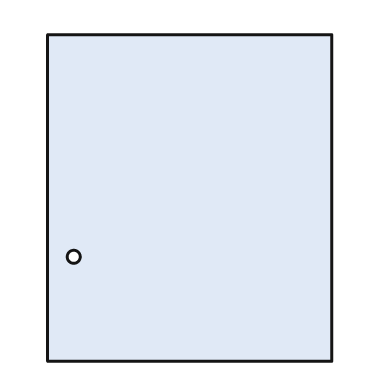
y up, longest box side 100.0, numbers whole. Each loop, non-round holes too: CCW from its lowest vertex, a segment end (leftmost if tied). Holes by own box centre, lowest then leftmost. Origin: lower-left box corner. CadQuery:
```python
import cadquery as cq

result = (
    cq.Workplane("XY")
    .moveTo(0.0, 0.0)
    .lineTo(87.0, 0.0)
    .lineTo(87.0, 100.0)
    .lineTo(0.0, 100.0)
    .close()
    .moveTo(8.0, 32.0)
    .circle(2.0)
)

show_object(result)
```